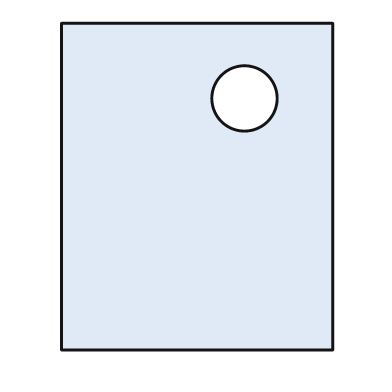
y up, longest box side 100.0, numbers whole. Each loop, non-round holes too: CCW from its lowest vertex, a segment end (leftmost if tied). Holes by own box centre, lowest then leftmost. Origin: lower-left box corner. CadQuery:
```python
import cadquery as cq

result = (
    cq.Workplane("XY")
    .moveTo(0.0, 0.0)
    .lineTo(83.0, 0.0)
    .lineTo(83.0, 100.0)
    .lineTo(0.0, 100.0)
    .close()
    .moveTo(56.0, 77.0)
    .circle(10.0)
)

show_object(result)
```